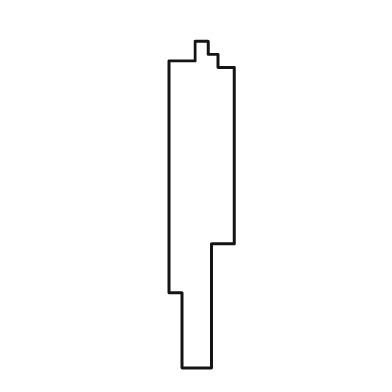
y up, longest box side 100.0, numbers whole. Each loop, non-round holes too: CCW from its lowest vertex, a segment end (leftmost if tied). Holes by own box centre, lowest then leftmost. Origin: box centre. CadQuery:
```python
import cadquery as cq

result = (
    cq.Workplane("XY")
    .moveTo(-6.0, -50.0)
    .lineTo(3.0, -50.0)
    .lineTo(3.0, -12.0)
    .lineTo(10.0, -12.0)
    .lineTo(10.0, 42.0)
    .lineTo(5.0, 42.0)
    .lineTo(5.0, 46.0)
    .lineTo(2.0, 46.0)
    .lineTo(2.0, 50.0)
    .lineTo(-2.0, 50.0)
    .lineTo(-2.0, 44.0)
    .lineTo(-10.0, 44.0)
    .lineTo(-10.0, -27.0)
    .lineTo(-6.0, -27.0)
    .close()
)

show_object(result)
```